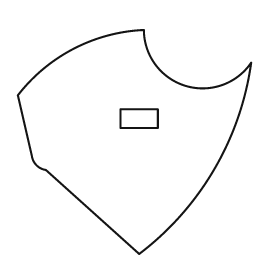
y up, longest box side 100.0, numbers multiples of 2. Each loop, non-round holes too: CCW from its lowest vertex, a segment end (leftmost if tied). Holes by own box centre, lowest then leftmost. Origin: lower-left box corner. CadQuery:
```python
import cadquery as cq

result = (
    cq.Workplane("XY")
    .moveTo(52.0, 0.0)
    .threePointArc((84.0, 36.0), (100.0, 82.0))
    .threePointArc((72.0, 72.0), (54.0, 96.0))
    .threePointArc((24.0, 88.0), (0.0, 68.0))
    .lineTo(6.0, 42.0)
    .threePointArc((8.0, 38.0), (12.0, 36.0))
    .close()
    .moveTo(44.0, 54.0)
    .lineTo(60.0, 54.0)
    .lineTo(60.0, 62.0)
    .lineTo(44.0, 62.0)
    .close()
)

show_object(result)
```